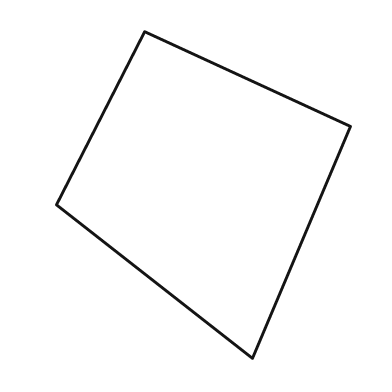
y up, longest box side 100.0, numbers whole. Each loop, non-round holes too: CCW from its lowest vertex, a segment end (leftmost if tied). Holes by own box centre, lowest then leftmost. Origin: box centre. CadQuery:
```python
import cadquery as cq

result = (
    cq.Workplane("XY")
    .moveTo(15.0, -50.0)
    .lineTo(45.0, 21.0)
    .lineTo(-18.0, 50.0)
    .lineTo(-45.0, -3.0)
    .close()
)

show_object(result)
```